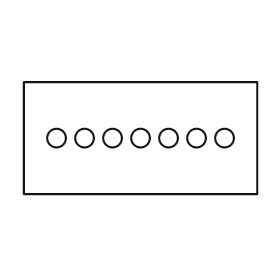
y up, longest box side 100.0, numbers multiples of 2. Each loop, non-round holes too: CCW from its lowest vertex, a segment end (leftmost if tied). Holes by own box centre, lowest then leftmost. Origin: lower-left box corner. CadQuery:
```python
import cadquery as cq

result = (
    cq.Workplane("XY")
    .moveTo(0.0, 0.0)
    .lineTo(100.0, 0.0)
    .lineTo(100.0, 48.0)
    .lineTo(0.0, 48.0)
    .close()
    .moveTo(14.0, 24.0)
    .circle(4.0)
    .moveTo(26.0, 24.0)
    .circle(4.0)
    .moveTo(38.0, 24.0)
    .circle(4.0)
    .moveTo(50.0, 24.0)
    .circle(4.0)
    .moveTo(62.0, 24.0)
    .circle(4.0)
    .moveTo(74.0, 24.0)
    .circle(4.0)
    .moveTo(86.0, 24.0)
    .circle(4.0)
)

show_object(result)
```